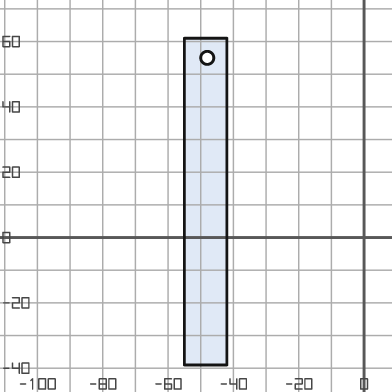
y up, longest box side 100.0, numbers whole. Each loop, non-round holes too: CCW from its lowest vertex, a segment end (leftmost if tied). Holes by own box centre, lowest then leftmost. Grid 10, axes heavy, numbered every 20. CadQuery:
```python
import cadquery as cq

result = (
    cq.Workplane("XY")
    .moveTo(-55.0, -39.0)
    .lineTo(-42.0, -39.0)
    .lineTo(-42.0, 61.0)
    .lineTo(-55.0, 61.0)
    .close()
    .moveTo(-48.0, 55.0)
    .circle(2.0)
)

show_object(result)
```